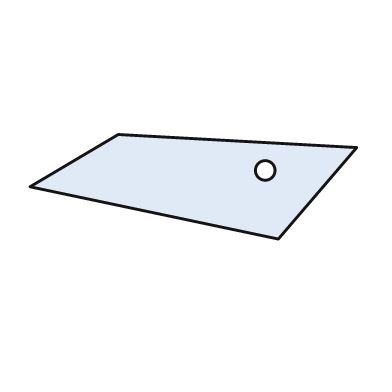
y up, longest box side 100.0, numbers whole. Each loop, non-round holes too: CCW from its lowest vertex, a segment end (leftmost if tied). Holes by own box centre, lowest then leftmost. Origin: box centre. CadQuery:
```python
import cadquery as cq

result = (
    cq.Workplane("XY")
    .moveTo(26.0, -16.0)
    .lineTo(50.0, 12.0)
    .lineTo(-23.0, 16.0)
    .lineTo(-50.0, 0.0)
    .close()
    .moveTo(22.0, 5.0)
    .circle(3.0)
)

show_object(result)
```